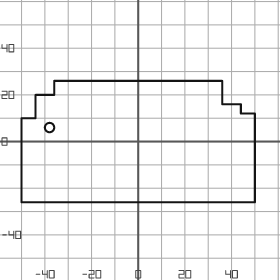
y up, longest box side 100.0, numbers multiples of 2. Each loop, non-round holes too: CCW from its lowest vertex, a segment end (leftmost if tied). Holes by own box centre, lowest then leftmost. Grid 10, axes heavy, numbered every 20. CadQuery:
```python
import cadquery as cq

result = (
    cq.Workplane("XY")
    .moveTo(-50.0, -26.0)
    .lineTo(50.0, -26.0)
    .lineTo(50.0, 12.0)
    .lineTo(44.0, 12.0)
    .lineTo(44.0, 16.0)
    .lineTo(36.0, 16.0)
    .lineTo(36.0, 26.0)
    .lineTo(-36.0, 26.0)
    .lineTo(-36.0, 20.0)
    .lineTo(-44.0, 20.0)
    .lineTo(-44.0, 10.0)
    .lineTo(-50.0, 10.0)
    .close()
    .moveTo(-38.0, 6.0)
    .circle(2.0)
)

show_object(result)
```